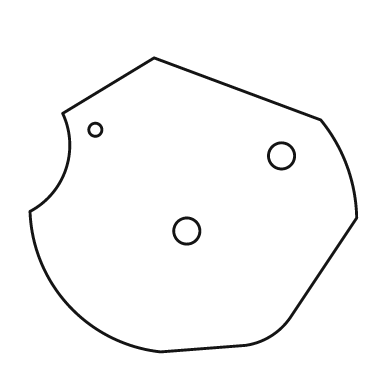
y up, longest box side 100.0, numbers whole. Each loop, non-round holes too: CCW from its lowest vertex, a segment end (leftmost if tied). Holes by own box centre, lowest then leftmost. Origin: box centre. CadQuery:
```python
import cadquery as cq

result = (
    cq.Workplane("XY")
    .moveTo(-10.0, -45.0)
    .lineTo(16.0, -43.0)
    .threePointArc((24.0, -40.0), (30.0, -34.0))
    .lineTo(50.0, -4.0)
    .threePointArc((47.0, 12.0), (39.0, 26.0))
    .lineTo(-12.0, 45.0)
    .lineTo(-40.0, 28.0)
    .threePointArc((-39.0, 11.0), (-50.0, -2.0))
    .threePointArc((-38.0, -31.0), (-10.0, -45.0))
    .close()
    .moveTo(-2.0, -8.0)
    .circle(4.0)
    .moveTo(27.0, 15.0)
    .circle(4.0)
    .moveTo(-30.0, 23.0)
    .circle(2.0)
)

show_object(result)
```